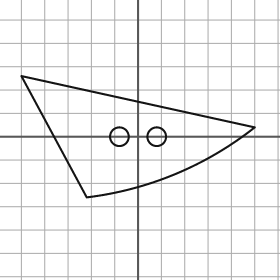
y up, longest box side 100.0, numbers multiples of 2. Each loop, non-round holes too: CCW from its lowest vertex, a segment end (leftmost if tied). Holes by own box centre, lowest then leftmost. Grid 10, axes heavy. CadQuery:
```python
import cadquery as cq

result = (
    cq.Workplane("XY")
    .moveTo(-22.0, -26.0)
    .threePointArc((16.0, -16.0), (50.0, 4.0))
    .lineTo(-50.0, 26.0)
    .close()
    .moveTo(-8.0, 0.0)
    .circle(4.0)
    .moveTo(8.0, 0.0)
    .circle(4.0)
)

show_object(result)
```